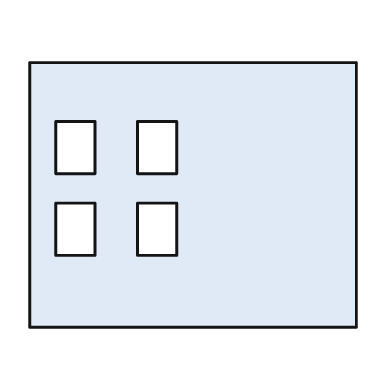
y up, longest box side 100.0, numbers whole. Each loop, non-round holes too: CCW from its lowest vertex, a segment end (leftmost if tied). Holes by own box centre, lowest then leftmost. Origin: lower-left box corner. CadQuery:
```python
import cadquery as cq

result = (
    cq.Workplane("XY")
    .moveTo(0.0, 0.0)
    .lineTo(100.0, 0.0)
    .lineTo(100.0, 81.0)
    .lineTo(0.0, 81.0)
    .close()
    .moveTo(8.0, 22.0)
    .lineTo(20.0, 22.0)
    .lineTo(20.0, 38.0)
    .lineTo(8.0, 38.0)
    .close()
    .moveTo(33.0, 22.0)
    .lineTo(45.0, 22.0)
    .lineTo(45.0, 38.0)
    .lineTo(33.0, 38.0)
    .close()
    .moveTo(8.0, 47.0)
    .lineTo(20.0, 47.0)
    .lineTo(20.0, 63.0)
    .lineTo(8.0, 63.0)
    .close()
    .moveTo(33.0, 47.0)
    .lineTo(45.0, 47.0)
    .lineTo(45.0, 63.0)
    .lineTo(33.0, 63.0)
    .close()
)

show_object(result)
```